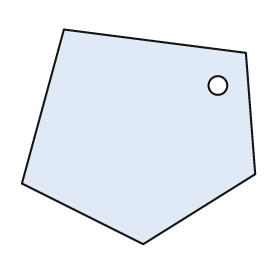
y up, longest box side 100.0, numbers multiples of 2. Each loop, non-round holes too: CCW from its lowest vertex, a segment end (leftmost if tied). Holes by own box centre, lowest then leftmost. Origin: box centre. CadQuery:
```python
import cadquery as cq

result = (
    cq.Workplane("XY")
    .moveTo(2.0, -46.0)
    .lineTo(50.0, -16.0)
    .lineTo(46.0, 36.0)
    .lineTo(-32.0, 46.0)
    .lineTo(-50.0, -20.0)
    .close()
    .moveTo(34.0, 22.0)
    .circle(4.0)
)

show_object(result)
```